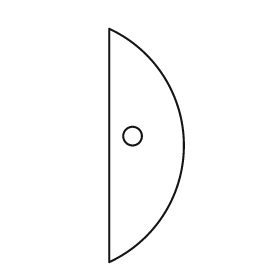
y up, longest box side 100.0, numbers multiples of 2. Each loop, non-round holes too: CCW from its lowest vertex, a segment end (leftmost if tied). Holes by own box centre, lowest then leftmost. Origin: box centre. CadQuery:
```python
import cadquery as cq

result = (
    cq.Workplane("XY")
    .moveTo(-16.0, -50.0)
    .threePointArc((16.0, 0.0), (-16.0, 50.0))
    .close()
    .moveTo(-6.0, 4.0)
    .circle(4.0)
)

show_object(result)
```